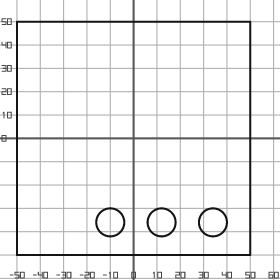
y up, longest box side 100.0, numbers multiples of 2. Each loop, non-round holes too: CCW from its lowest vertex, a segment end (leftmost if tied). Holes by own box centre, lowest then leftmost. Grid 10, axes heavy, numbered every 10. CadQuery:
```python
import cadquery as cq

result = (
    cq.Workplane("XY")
    .moveTo(-50.0, -50.0)
    .lineTo(50.0, -50.0)
    .lineTo(50.0, 50.0)
    .lineTo(-50.0, 50.0)
    .close()
    .moveTo(-10.0, -36.0)
    .circle(6.0)
    .moveTo(12.0, -36.0)
    .circle(6.0)
    .moveTo(34.0, -36.0)
    .circle(6.0)
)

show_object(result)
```